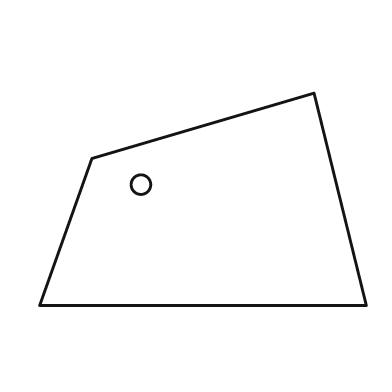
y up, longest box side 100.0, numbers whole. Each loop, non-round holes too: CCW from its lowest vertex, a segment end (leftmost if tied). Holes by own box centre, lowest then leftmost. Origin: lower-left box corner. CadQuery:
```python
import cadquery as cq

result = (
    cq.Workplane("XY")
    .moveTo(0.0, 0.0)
    .lineTo(100.0, 0.0)
    .lineTo(84.0, 65.0)
    .lineTo(16.0, 45.0)
    .close()
    .moveTo(31.0, 37.0)
    .circle(3.0)
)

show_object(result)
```